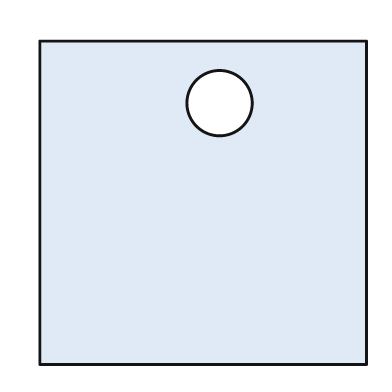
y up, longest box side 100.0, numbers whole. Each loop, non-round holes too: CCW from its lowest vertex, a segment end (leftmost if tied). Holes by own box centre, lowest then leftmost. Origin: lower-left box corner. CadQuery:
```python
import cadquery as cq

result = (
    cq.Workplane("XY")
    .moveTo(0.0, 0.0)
    .lineTo(100.0, 0.0)
    .lineTo(100.0, 99.0)
    .lineTo(0.0, 99.0)
    .close()
    .moveTo(55.0, 80.0)
    .circle(10.0)
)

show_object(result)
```